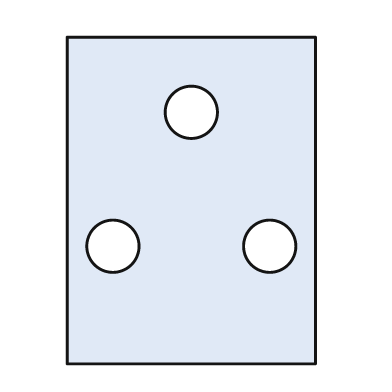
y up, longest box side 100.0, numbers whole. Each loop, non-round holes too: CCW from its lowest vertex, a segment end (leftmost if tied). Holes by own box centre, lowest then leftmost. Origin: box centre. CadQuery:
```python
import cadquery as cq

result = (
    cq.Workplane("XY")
    .moveTo(-38.0, -50.0)
    .lineTo(38.0, -50.0)
    .lineTo(38.0, 50.0)
    .lineTo(-38.0, 50.0)
    .close()
    .moveTo(-24.0, -14.0)
    .circle(8.0)
    .moveTo(24.0, -14.0)
    .circle(8.0)
    .moveTo(0.0, 27.0)
    .circle(8.0)
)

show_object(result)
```